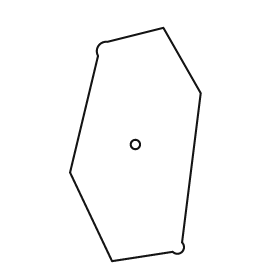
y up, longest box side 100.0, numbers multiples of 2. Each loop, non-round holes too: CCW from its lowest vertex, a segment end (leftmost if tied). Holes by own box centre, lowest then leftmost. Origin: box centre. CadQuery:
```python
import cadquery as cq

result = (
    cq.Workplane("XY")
    .moveTo(-10.0, -50.0)
    .lineTo(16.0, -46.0)
    .threePointArc((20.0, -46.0), (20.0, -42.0))
    .lineTo(28.0, 22.0)
    .lineTo(12.0, 50.0)
    .lineTo(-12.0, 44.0)
    .threePointArc((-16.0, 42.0), (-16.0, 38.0))
    .lineTo(-28.0, -12.0)
    .close()
    .moveTo(0.0, 0.0)
    .circle(2.0)
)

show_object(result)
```